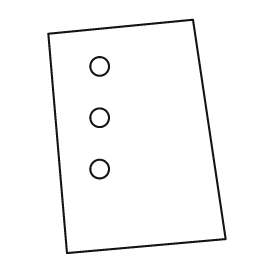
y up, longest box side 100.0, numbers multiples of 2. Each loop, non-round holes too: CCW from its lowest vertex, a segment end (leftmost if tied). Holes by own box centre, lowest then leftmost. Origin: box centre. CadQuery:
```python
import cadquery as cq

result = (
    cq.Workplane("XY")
    .moveTo(-30.0, -50.0)
    .lineTo(38.0, -44.0)
    .lineTo(24.0, 50.0)
    .lineTo(-38.0, 44.0)
    .close()
    .moveTo(-16.0, -14.0)
    .circle(4.0)
    .moveTo(-16.0, 8.0)
    .circle(4.0)
    .moveTo(-16.0, 30.0)
    .circle(4.0)
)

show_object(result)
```